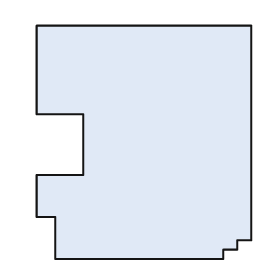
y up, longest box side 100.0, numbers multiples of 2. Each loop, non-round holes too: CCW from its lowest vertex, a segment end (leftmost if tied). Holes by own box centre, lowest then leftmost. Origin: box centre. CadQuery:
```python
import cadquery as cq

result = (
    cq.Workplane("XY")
    .moveTo(-38.0, -50.0)
    .lineTo(34.0, -50.0)
    .lineTo(34.0, -46.0)
    .lineTo(40.0, -46.0)
    .lineTo(40.0, -42.0)
    .lineTo(46.0, -42.0)
    .lineTo(46.0, 50.0)
    .lineTo(-46.0, 50.0)
    .lineTo(-46.0, 12.0)
    .lineTo(-26.0, 12.0)
    .lineTo(-26.0, -14.0)
    .lineTo(-46.0, -14.0)
    .lineTo(-46.0, -32.0)
    .lineTo(-38.0, -32.0)
    .close()
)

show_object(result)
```